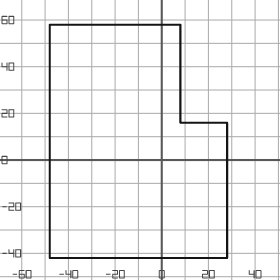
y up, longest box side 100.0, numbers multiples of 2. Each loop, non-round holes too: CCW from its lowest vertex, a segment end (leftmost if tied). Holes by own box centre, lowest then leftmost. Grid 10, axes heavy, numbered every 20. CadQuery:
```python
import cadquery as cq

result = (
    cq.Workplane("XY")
    .moveTo(-48.0, -42.0)
    .lineTo(28.0, -42.0)
    .lineTo(28.0, 16.0)
    .lineTo(8.0, 16.0)
    .lineTo(8.0, 58.0)
    .lineTo(-48.0, 58.0)
    .close()
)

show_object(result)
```